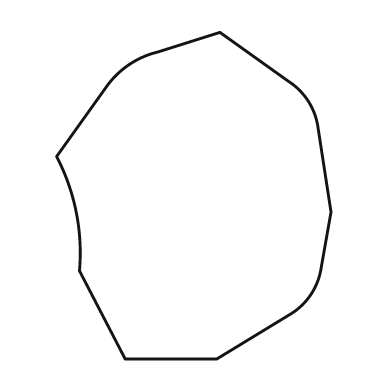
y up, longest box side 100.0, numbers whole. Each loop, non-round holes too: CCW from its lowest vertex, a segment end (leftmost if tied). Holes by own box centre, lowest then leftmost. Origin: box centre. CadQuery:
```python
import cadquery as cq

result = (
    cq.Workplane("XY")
    .moveTo(-21.0, -50.0)
    .lineTo(7.0, -50.0)
    .lineTo(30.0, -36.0)
    .threePointArc((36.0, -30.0), (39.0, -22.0))
    .lineTo(42.0, -5.0)
    .lineTo(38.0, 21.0)
    .threePointArc((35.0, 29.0), (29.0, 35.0))
    .lineTo(8.0, 50.0)
    .lineTo(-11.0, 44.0)
    .threePointArc((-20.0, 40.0), (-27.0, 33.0))
    .lineTo(-42.0, 12.0)
    .threePointArc((-36.0, -5.0), (-35.0, -23.0))
    .close()
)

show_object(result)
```